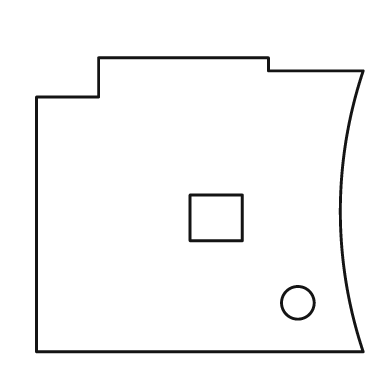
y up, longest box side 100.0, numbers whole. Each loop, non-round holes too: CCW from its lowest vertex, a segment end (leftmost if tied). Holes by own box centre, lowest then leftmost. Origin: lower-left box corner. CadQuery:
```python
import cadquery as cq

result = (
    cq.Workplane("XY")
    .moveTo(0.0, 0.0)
    .lineTo(100.0, 0.0)
    .threePointArc((93.0, 43.0), (100.0, 86.0))
    .lineTo(71.0, 86.0)
    .lineTo(71.0, 90.0)
    .lineTo(19.0, 90.0)
    .lineTo(19.0, 78.0)
    .lineTo(0.0, 78.0)
    .close()
    .moveTo(80.0, 15.0)
    .circle(5.0)
    .moveTo(47.0, 34.0)
    .lineTo(63.0, 34.0)
    .lineTo(63.0, 48.0)
    .lineTo(47.0, 48.0)
    .close()
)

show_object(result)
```